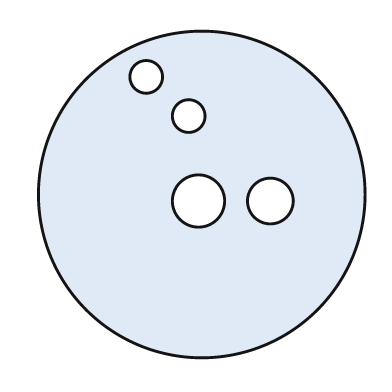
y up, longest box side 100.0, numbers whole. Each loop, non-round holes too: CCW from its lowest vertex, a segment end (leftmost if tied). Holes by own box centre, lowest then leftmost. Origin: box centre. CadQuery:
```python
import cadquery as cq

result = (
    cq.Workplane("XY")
    .moveTo(0.0, 0.0)
    .circle(50.0)
    .moveTo(-1.0, -2.0)
    .circle(8.0)
    .moveTo(21.0, -2.0)
    .circle(7.0)
    .moveTo(-4.0, 24.0)
    .circle(5.0)
    .moveTo(-17.0, 36.0)
    .circle(5.0)
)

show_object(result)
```